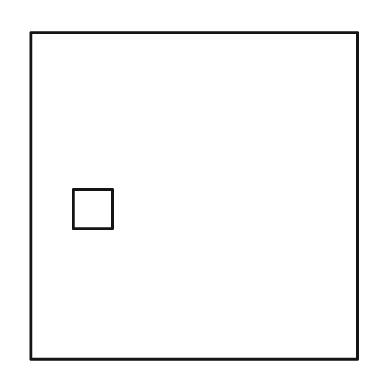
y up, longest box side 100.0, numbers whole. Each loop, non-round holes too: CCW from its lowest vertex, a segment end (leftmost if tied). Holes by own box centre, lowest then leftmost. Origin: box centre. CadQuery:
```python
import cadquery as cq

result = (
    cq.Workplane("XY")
    .moveTo(-50.0, -50.0)
    .lineTo(50.0, -50.0)
    .lineTo(50.0, 50.0)
    .lineTo(-50.0, 50.0)
    .close()
    .moveTo(-37.0, -10.0)
    .lineTo(-25.0, -10.0)
    .lineTo(-25.0, 2.0)
    .lineTo(-37.0, 2.0)
    .close()
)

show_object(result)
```